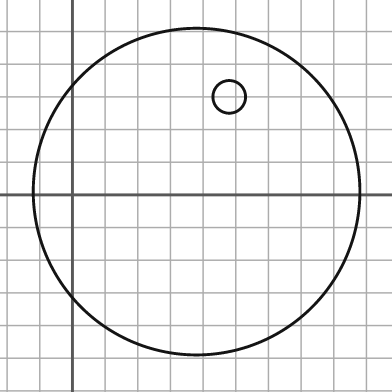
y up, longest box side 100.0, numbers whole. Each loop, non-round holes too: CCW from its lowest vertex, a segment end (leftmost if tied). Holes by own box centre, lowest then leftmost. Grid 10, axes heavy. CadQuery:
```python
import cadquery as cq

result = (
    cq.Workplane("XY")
    .moveTo(38.0, 1.0)
    .circle(50.0)
    .moveTo(48.0, 30.0)
    .circle(5.0)
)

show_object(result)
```